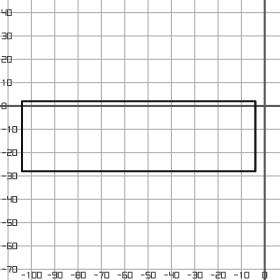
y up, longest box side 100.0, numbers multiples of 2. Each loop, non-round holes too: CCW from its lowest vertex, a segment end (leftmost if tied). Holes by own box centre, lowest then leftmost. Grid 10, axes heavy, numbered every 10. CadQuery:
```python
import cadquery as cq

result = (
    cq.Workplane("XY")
    .moveTo(-104.0, -28.0)
    .lineTo(-4.0, -28.0)
    .lineTo(-4.0, 2.0)
    .lineTo(-104.0, 2.0)
    .close()
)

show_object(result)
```